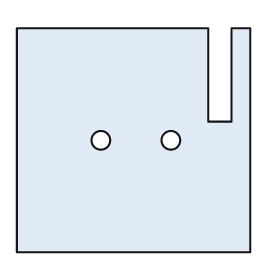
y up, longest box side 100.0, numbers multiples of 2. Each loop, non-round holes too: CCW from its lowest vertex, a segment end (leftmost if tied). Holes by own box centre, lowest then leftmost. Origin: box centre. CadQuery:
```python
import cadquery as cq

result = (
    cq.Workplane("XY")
    .moveTo(-50.0, -48.0)
    .lineTo(50.0, -48.0)
    .lineTo(50.0, 48.0)
    .lineTo(42.0, 48.0)
    .lineTo(42.0, 8.0)
    .lineTo(32.0, 8.0)
    .lineTo(32.0, 48.0)
    .lineTo(-50.0, 48.0)
    .close()
    .moveTo(-14.0, 0.0)
    .circle(4.0)
    .moveTo(16.0, 0.0)
    .circle(4.0)
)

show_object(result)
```